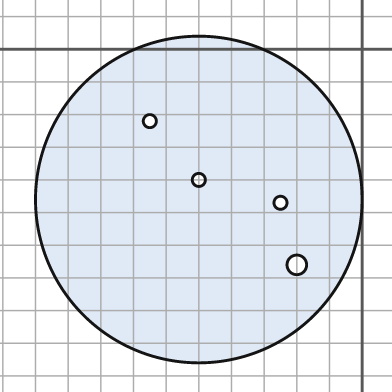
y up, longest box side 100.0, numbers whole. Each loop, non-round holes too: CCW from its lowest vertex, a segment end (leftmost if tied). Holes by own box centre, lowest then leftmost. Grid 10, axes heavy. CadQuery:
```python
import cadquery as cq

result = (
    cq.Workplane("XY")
    .moveTo(-50.0, -46.0)
    .circle(50.0)
    .moveTo(-20.0, -66.0)
    .circle(3.0)
    .moveTo(-25.0, -47.0)
    .circle(2.0)
    .moveTo(-50.0, -40.0)
    .circle(2.0)
    .moveTo(-65.0, -22.0)
    .circle(2.0)
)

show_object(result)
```